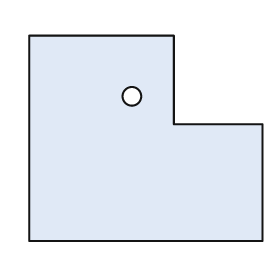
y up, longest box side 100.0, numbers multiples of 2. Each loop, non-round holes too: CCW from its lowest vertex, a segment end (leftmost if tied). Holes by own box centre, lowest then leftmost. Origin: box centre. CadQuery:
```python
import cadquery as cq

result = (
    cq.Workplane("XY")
    .moveTo(-50.0, -44.0)
    .lineTo(50.0, -44.0)
    .lineTo(50.0, 6.0)
    .lineTo(12.0, 6.0)
    .lineTo(12.0, 44.0)
    .lineTo(-50.0, 44.0)
    .close()
    .moveTo(-6.0, 18.0)
    .circle(4.0)
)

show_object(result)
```